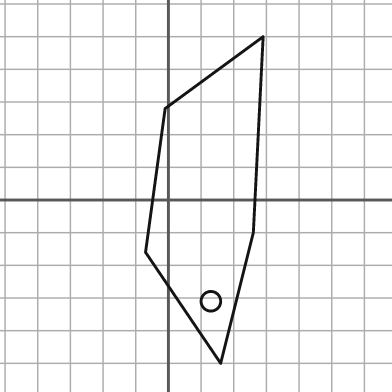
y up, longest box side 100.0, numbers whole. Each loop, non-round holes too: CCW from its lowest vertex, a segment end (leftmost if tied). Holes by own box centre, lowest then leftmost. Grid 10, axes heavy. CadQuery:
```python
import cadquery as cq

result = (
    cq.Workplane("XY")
    .moveTo(16.0, -50.0)
    .lineTo(26.0, -10.0)
    .lineTo(29.0, 50.0)
    .lineTo(-1.0, 28.0)
    .lineTo(-7.0, -16.0)
    .close()
    .moveTo(13.0, -31.0)
    .circle(3.0)
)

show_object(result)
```